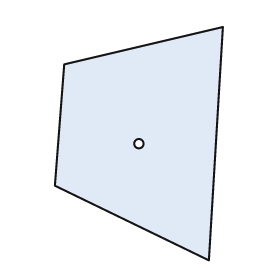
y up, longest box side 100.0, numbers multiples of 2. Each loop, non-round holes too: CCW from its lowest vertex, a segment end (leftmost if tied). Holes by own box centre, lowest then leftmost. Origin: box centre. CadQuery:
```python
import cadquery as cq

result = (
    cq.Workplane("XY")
    .moveTo(30.0, -50.0)
    .lineTo(36.0, 50.0)
    .lineTo(-32.0, 34.0)
    .lineTo(-36.0, -18.0)
    .close()
    .moveTo(0.0, 0.0)
    .circle(2.0)
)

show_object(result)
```